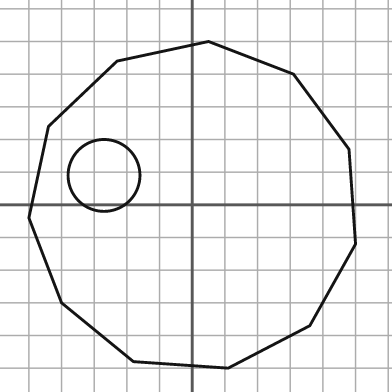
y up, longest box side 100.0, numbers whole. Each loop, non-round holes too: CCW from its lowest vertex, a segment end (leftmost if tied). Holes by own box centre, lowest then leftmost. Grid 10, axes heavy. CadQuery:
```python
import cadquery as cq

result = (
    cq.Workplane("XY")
    .moveTo(11.0, -50.0)
    .lineTo(36.0, -37.0)
    .lineTo(50.0, -12.0)
    .lineTo(48.0, 17.0)
    .lineTo(31.0, 40.0)
    .lineTo(5.0, 50.0)
    .lineTo(-23.0, 44.0)
    .lineTo(-44.0, 24.0)
    .lineTo(-50.0, -4.0)
    .lineTo(-40.0, -30.0)
    .lineTo(-18.0, -48.0)
    .close()
    .moveTo(-27.0, 9.0)
    .circle(11.0)
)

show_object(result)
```